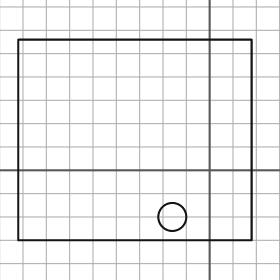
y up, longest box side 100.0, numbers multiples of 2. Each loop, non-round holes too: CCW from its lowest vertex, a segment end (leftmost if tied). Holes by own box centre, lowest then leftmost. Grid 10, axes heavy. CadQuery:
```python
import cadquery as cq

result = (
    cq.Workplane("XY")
    .moveTo(-82.0, -30.0)
    .lineTo(18.0, -30.0)
    .lineTo(18.0, 56.0)
    .lineTo(-82.0, 56.0)
    .close()
    .moveTo(-16.0, -20.0)
    .circle(6.0)
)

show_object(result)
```